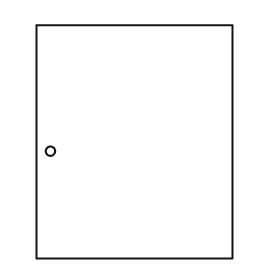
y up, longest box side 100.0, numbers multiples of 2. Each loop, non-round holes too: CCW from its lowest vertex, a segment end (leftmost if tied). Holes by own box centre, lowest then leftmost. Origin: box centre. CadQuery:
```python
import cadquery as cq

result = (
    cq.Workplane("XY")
    .moveTo(-42.0, -50.0)
    .lineTo(42.0, -50.0)
    .lineTo(42.0, 50.0)
    .lineTo(-42.0, 50.0)
    .close()
    .moveTo(-36.0, -4.0)
    .circle(2.0)
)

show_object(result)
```